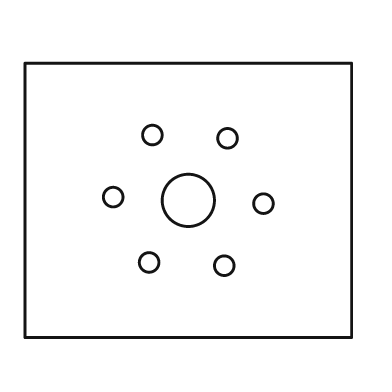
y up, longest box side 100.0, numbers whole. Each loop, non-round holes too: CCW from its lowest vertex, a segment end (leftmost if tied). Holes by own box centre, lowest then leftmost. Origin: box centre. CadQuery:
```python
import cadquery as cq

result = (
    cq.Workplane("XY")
    .moveTo(-50.0, -42.0)
    .lineTo(50.0, -42.0)
    .lineTo(50.0, 42.0)
    .lineTo(-50.0, 42.0)
    .close()
    .moveTo(11.0, -20.0)
    .circle(3.0)
    .moveTo(-12.0, -19.0)
    .circle(3.0)
    .moveTo(23.0, -1.0)
    .circle(3.0)
    .moveTo(0.0, 0.0)
    .circle(8.0)
    .moveTo(-23.0, 1.0)
    .circle(3.0)
    .moveTo(12.0, 19.0)
    .circle(3.0)
    .moveTo(-11.0, 20.0)
    .circle(3.0)
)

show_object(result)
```